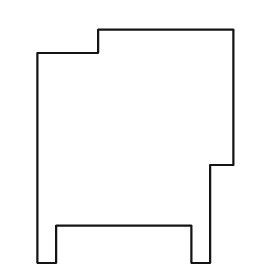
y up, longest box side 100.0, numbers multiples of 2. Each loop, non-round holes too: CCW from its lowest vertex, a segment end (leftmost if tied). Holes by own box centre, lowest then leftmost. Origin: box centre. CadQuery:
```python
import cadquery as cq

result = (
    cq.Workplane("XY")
    .moveTo(-42.0, -50.0)
    .lineTo(-34.0, -50.0)
    .lineTo(-34.0, -34.0)
    .lineTo(24.0, -34.0)
    .lineTo(24.0, -50.0)
    .lineTo(32.0, -50.0)
    .lineTo(32.0, -8.0)
    .lineTo(42.0, -8.0)
    .lineTo(42.0, 50.0)
    .lineTo(-16.0, 50.0)
    .lineTo(-16.0, 40.0)
    .lineTo(-42.0, 40.0)
    .close()
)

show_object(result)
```